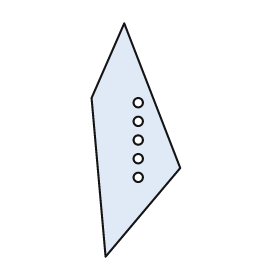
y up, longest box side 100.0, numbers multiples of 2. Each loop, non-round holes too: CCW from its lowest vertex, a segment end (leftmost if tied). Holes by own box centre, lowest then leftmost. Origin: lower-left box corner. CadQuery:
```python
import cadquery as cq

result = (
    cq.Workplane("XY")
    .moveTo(6.0, 0.0)
    .lineTo(38.0, 38.0)
    .lineTo(14.0, 100.0)
    .lineTo(0.0, 68.0)
    .close()
    .moveTo(20.0, 34.0)
    .circle(2.0)
    .moveTo(20.0, 42.0)
    .circle(2.0)
    .moveTo(20.0, 50.0)
    .circle(2.0)
    .moveTo(20.0, 58.0)
    .circle(2.0)
    .moveTo(20.0, 66.0)
    .circle(2.0)
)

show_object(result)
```